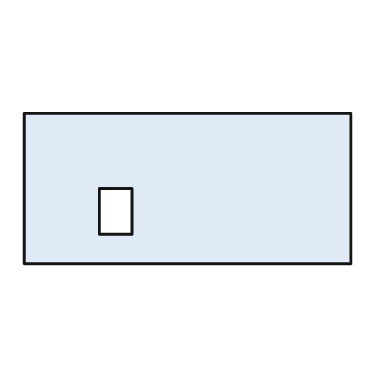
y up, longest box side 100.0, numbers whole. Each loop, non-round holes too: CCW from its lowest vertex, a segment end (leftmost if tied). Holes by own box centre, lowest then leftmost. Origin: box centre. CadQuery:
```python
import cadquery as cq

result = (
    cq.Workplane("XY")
    .moveTo(-50.0, -23.0)
    .lineTo(50.0, -23.0)
    .lineTo(50.0, 23.0)
    .lineTo(-50.0, 23.0)
    .close()
    .moveTo(-27.0, -14.0)
    .lineTo(-17.0, -14.0)
    .lineTo(-17.0, 0.0)
    .lineTo(-27.0, 0.0)
    .close()
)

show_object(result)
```